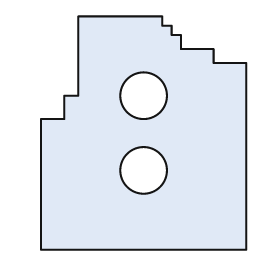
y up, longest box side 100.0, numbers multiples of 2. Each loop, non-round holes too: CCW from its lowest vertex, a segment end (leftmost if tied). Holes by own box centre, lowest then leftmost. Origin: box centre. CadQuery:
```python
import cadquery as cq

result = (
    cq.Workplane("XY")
    .moveTo(-44.0, -50.0)
    .lineTo(44.0, -50.0)
    .lineTo(44.0, 30.0)
    .lineTo(30.0, 30.0)
    .lineTo(30.0, 36.0)
    .lineTo(16.0, 36.0)
    .lineTo(16.0, 42.0)
    .lineTo(12.0, 42.0)
    .lineTo(12.0, 46.0)
    .lineTo(8.0, 46.0)
    .lineTo(8.0, 50.0)
    .lineTo(-28.0, 50.0)
    .lineTo(-28.0, 16.0)
    .lineTo(-34.0, 16.0)
    .lineTo(-34.0, 6.0)
    .lineTo(-44.0, 6.0)
    .close()
    .moveTo(0.0, -16.0)
    .circle(10.0)
    .moveTo(0.0, 16.0)
    .circle(10.0)
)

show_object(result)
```